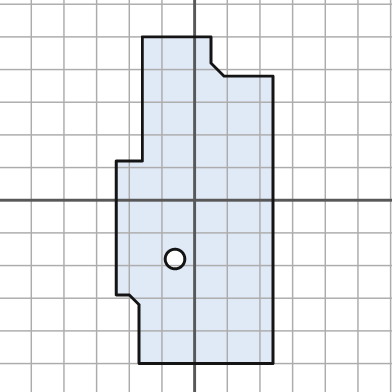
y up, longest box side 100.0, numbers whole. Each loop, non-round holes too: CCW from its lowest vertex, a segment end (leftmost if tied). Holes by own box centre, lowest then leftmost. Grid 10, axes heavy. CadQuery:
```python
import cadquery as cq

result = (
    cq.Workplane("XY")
    .moveTo(-17.0, -50.0)
    .lineTo(24.0, -50.0)
    .lineTo(24.0, 38.0)
    .lineTo(9.0, 38.0)
    .lineTo(5.0, 42.0)
    .lineTo(5.0, 50.0)
    .lineTo(-16.0, 50.0)
    .lineTo(-16.0, 12.0)
    .lineTo(-24.0, 12.0)
    .lineTo(-24.0, -29.0)
    .lineTo(-20.0, -29.0)
    .lineTo(-17.0, -32.0)
    .close()
    .moveTo(-6.0, -18.0)
    .circle(3.0)
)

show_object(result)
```